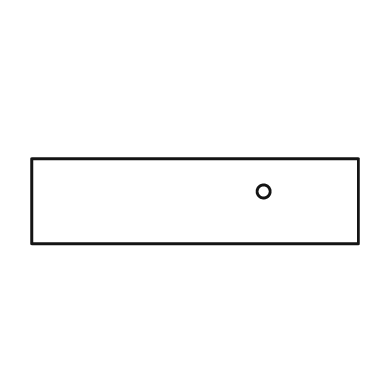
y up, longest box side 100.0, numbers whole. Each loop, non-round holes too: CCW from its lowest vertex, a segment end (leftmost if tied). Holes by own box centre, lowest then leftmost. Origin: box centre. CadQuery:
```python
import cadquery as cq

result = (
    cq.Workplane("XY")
    .moveTo(-50.0, -13.0)
    .lineTo(50.0, -13.0)
    .lineTo(50.0, 13.0)
    .lineTo(-50.0, 13.0)
    .close()
    .moveTo(21.0, 3.0)
    .circle(2.0)
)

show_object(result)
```